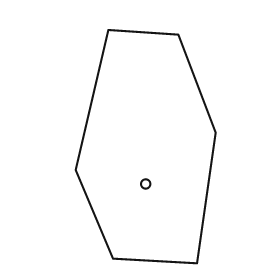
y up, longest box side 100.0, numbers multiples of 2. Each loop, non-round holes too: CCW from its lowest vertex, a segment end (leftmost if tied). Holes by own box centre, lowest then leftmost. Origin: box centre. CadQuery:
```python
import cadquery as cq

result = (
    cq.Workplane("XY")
    .moveTo(22.0, -50.0)
    .lineTo(30.0, 6.0)
    .lineTo(14.0, 48.0)
    .lineTo(-16.0, 50.0)
    .lineTo(-30.0, -10.0)
    .lineTo(-14.0, -48.0)
    .close()
    .moveTo(0.0, -16.0)
    .circle(2.0)
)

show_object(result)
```